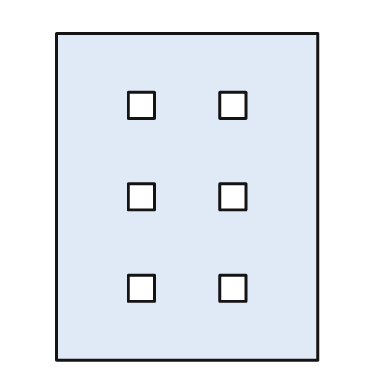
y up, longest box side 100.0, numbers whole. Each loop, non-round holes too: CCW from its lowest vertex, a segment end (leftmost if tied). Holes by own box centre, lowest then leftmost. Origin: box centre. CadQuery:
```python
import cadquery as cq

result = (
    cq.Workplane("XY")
    .moveTo(-40.0, -50.0)
    .lineTo(40.0, -50.0)
    .lineTo(40.0, 50.0)
    .lineTo(-40.0, 50.0)
    .close()
    .moveTo(-18.0, -32.0)
    .lineTo(-10.0, -32.0)
    .lineTo(-10.0, -24.0)
    .lineTo(-18.0, -24.0)
    .close()
    .moveTo(10.0, -32.0)
    .lineTo(18.0, -32.0)
    .lineTo(18.0, -24.0)
    .lineTo(10.0, -24.0)
    .close()
    .moveTo(-18.0, -4.0)
    .lineTo(-10.0, -4.0)
    .lineTo(-10.0, 4.0)
    .lineTo(-18.0, 4.0)
    .close()
    .moveTo(10.0, -4.0)
    .lineTo(18.0, -4.0)
    .lineTo(18.0, 4.0)
    .lineTo(10.0, 4.0)
    .close()
    .moveTo(-18.0, 24.0)
    .lineTo(-10.0, 24.0)
    .lineTo(-10.0, 32.0)
    .lineTo(-18.0, 32.0)
    .close()
    .moveTo(10.0, 24.0)
    .lineTo(18.0, 24.0)
    .lineTo(18.0, 32.0)
    .lineTo(10.0, 32.0)
    .close()
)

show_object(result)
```